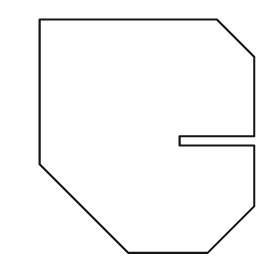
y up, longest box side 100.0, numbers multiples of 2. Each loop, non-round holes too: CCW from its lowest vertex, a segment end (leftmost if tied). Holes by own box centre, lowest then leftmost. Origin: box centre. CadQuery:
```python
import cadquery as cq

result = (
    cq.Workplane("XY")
    .moveTo(-8.0, -50.0)
    .lineTo(26.0, -50.0)
    .lineTo(46.0, -30.0)
    .lineTo(46.0, -4.0)
    .lineTo(14.0, -4.0)
    .lineTo(14.0, 0.0)
    .lineTo(46.0, 0.0)
    .lineTo(46.0, 34.0)
    .lineTo(30.0, 50.0)
    .lineTo(-46.0, 50.0)
    .lineTo(-46.0, -12.0)
    .close()
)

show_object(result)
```